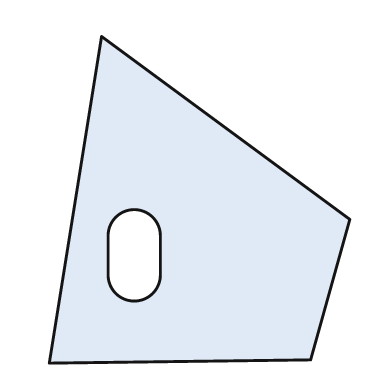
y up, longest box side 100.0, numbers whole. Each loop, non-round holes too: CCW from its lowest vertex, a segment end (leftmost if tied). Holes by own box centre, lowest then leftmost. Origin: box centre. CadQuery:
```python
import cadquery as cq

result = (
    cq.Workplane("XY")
    .moveTo(-46.0, -50.0)
    .lineTo(34.0, -49.0)
    .lineTo(46.0, -6.0)
    .lineTo(-30.0, 50.0)
    .close()
    .moveTo(-28.0, -23.0)
    .threePointArc((-20.0, -31.0), (-12.0, -23.0))
    .lineTo(-12.0, -11.0)
    .threePointArc((-20.0, -3.0), (-28.0, -11.0))
    .close()
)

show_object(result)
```